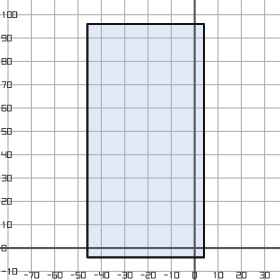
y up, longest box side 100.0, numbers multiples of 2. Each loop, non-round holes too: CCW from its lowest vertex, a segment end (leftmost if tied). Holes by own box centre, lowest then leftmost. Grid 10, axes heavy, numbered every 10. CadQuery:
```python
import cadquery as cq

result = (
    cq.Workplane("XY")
    .moveTo(-46.0, -4.0)
    .lineTo(4.0, -4.0)
    .lineTo(4.0, 96.0)
    .lineTo(-46.0, 96.0)
    .close()
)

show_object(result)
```